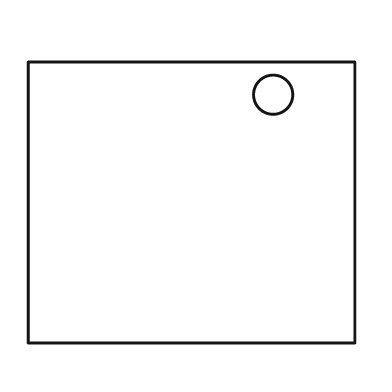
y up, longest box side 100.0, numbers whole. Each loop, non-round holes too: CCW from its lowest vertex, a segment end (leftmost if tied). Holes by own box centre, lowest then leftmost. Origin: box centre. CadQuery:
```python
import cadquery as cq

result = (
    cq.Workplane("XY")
    .moveTo(-50.0, -43.0)
    .lineTo(50.0, -43.0)
    .lineTo(50.0, 43.0)
    .lineTo(-50.0, 43.0)
    .close()
    .moveTo(25.0, 33.0)
    .circle(6.0)
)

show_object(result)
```